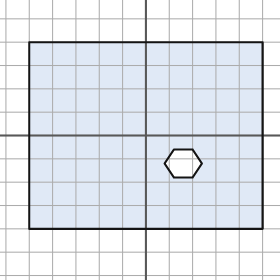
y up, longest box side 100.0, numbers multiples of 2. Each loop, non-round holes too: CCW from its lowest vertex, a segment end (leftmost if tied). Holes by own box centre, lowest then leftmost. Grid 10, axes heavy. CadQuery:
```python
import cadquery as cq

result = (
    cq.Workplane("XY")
    .moveTo(-50.0, -40.0)
    .lineTo(50.0, -40.0)
    .lineTo(50.0, 40.0)
    .lineTo(-50.0, 40.0)
    .close()
    .moveTo(12.0, -18.0)
    .lineTo(20.0, -18.0)
    .lineTo(24.0, -12.0)
    .lineTo(20.0, -6.0)
    .lineTo(12.0, -6.0)
    .lineTo(8.0, -12.0)
    .close()
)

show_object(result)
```